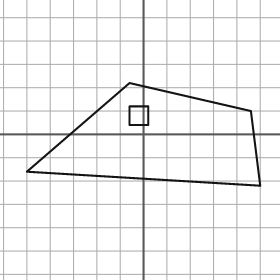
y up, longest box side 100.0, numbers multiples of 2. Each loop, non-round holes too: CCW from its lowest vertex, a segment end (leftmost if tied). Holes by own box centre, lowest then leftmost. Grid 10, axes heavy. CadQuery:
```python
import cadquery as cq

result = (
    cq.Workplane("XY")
    .moveTo(50.0, -22.0)
    .lineTo(46.0, 10.0)
    .lineTo(-6.0, 22.0)
    .lineTo(-50.0, -16.0)
    .close()
    .moveTo(-6.0, 4.0)
    .lineTo(2.0, 4.0)
    .lineTo(2.0, 12.0)
    .lineTo(-6.0, 12.0)
    .close()
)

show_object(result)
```